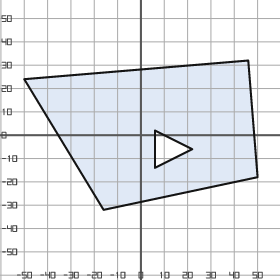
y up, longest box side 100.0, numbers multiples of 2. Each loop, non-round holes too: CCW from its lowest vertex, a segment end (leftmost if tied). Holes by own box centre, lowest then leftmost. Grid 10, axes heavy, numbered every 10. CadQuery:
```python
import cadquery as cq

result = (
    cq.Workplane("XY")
    .moveTo(-16.0, -32.0)
    .lineTo(50.0, -18.0)
    .lineTo(46.0, 32.0)
    .lineTo(-50.0, 24.0)
    .close()
    .moveTo(6.0, -14.0)
    .lineTo(22.0, -6.0)
    .lineTo(6.0, 2.0)
    .close()
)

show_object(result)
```